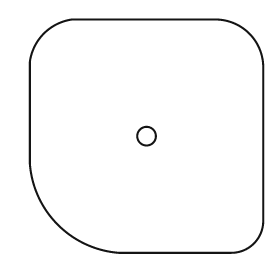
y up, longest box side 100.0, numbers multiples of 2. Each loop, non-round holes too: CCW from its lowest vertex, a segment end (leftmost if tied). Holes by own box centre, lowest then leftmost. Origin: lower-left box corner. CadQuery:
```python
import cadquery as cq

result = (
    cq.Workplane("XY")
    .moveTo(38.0, 0.0)
    .lineTo(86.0, 0.0)
    .threePointArc((96.0, 4.0), (100.0, 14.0))
    .lineTo(100.0, 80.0)
    .threePointArc((94.0, 94.0), (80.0, 100.0))
    .lineTo(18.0, 100.0)
    .threePointArc((6.0, 94.0), (0.0, 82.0))
    .lineTo(0.0, 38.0)
    .threePointArc((12.0, 12.0), (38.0, 0.0))
    .close()
    .moveTo(50.0, 50.0)
    .circle(4.0)
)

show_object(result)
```